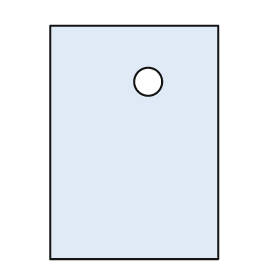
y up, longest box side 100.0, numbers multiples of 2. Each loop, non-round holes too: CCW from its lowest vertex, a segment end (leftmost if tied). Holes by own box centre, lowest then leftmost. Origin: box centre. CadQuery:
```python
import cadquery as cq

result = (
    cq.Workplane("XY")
    .moveTo(-36.0, -50.0)
    .lineTo(36.0, -50.0)
    .lineTo(36.0, 50.0)
    .lineTo(-36.0, 50.0)
    .close()
    .moveTo(6.0, 26.0)
    .circle(6.0)
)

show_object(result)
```